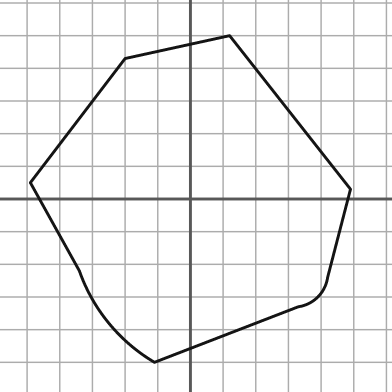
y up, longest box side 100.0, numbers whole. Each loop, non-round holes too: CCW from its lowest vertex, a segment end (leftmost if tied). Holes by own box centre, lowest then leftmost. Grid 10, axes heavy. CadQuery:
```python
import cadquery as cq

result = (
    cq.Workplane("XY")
    .moveTo(-11.0, -50.0)
    .lineTo(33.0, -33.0)
    .threePointArc((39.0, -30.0), (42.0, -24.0))
    .lineTo(49.0, 3.0)
    .lineTo(12.0, 50.0)
    .lineTo(-20.0, 43.0)
    .lineTo(-49.0, 5.0)
    .lineTo(-34.0, -22.0)
    .threePointArc((-25.0, -38.0), (-11.0, -50.0))
    .close()
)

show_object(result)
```